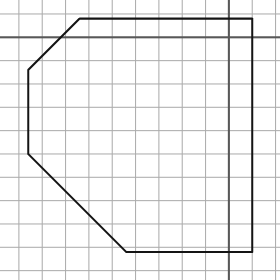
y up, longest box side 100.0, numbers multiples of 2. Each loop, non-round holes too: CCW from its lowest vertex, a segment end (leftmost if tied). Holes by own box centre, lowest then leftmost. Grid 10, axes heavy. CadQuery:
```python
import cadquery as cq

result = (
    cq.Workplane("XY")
    .moveTo(-44.0, -92.0)
    .lineTo(10.0, -92.0)
    .lineTo(10.0, 8.0)
    .lineTo(-64.0, 8.0)
    .lineTo(-86.0, -14.0)
    .lineTo(-86.0, -50.0)
    .close()
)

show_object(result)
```